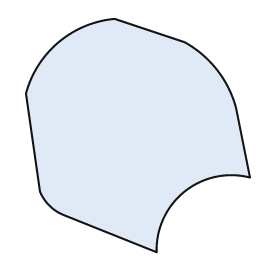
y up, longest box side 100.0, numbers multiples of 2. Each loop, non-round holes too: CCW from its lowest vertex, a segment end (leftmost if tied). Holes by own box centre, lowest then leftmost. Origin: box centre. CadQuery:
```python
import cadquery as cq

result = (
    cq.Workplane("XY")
    .moveTo(8.0, -50.0)
    .threePointArc((20.0, -24.0), (48.0, -18.0))
    .lineTo(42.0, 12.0)
    .threePointArc((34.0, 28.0), (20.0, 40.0))
    .lineTo(-10.0, 50.0)
    .threePointArc((-34.0, 40.0), (-48.0, 18.0))
    .lineTo(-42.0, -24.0)
    .threePointArc((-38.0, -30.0), (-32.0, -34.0))
    .close()
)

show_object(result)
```